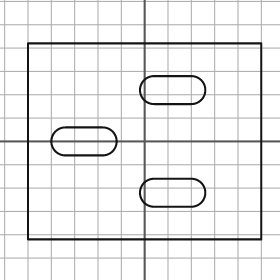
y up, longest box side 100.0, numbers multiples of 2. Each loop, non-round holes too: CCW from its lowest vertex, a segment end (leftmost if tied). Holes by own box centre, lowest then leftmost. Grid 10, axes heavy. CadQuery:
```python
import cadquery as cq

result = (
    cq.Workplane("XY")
    .moveTo(-50.0, -42.0)
    .lineTo(50.0, -42.0)
    .lineTo(50.0, 42.0)
    .lineTo(-50.0, 42.0)
    .close()
    .moveTo(4.0, -28.0)
    .lineTo(20.0, -28.0)
    .threePointArc((26.0, -22.0), (20.0, -16.0))
    .lineTo(4.0, -16.0)
    .threePointArc((-2.0, -22.0), (4.0, -28.0))
    .close()
    .moveTo(-34.0, -6.0)
    .lineTo(-18.0, -6.0)
    .threePointArc((-12.0, 0.0), (-18.0, 6.0))
    .lineTo(-34.0, 6.0)
    .threePointArc((-40.0, 0.0), (-34.0, -6.0))
    .close()
    .moveTo(4.0, 16.0)
    .lineTo(20.0, 16.0)
    .threePointArc((26.0, 22.0), (20.0, 28.0))
    .lineTo(4.0, 28.0)
    .threePointArc((-2.0, 22.0), (4.0, 16.0))
    .close()
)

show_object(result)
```